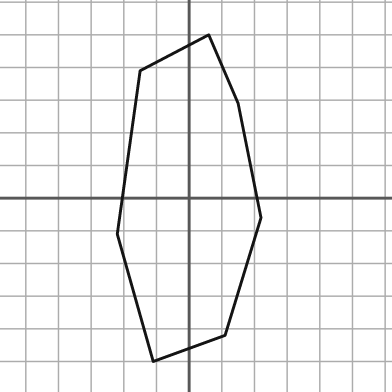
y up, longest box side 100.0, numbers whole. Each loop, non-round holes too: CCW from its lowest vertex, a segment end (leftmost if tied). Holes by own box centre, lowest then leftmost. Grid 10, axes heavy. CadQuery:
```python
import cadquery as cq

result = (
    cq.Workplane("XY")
    .moveTo(-11.0, -50.0)
    .lineTo(11.0, -42.0)
    .lineTo(22.0, -6.0)
    .lineTo(15.0, 29.0)
    .lineTo(6.0, 50.0)
    .lineTo(-15.0, 39.0)
    .lineTo(-22.0, -11.0)
    .close()
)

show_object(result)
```